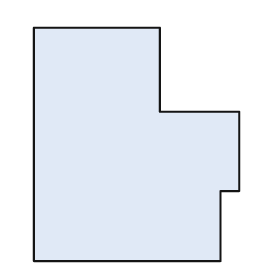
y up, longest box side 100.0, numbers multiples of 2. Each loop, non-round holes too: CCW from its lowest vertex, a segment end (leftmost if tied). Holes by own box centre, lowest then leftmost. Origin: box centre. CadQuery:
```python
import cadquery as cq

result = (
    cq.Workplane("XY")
    .moveTo(-44.0, -50.0)
    .lineTo(36.0, -50.0)
    .lineTo(36.0, -20.0)
    .lineTo(44.0, -20.0)
    .lineTo(44.0, 14.0)
    .lineTo(10.0, 14.0)
    .lineTo(10.0, 50.0)
    .lineTo(-44.0, 50.0)
    .close()
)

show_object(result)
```